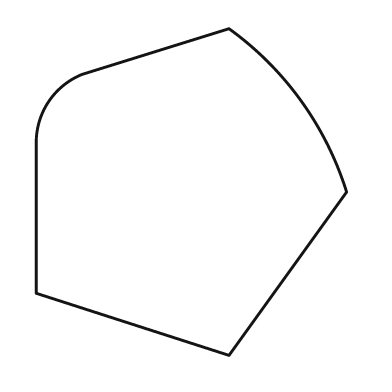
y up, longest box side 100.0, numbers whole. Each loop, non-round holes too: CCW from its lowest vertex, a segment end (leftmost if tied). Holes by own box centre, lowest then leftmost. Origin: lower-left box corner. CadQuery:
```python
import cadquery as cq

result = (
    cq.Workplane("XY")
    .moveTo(59.0, 0.0)
    .lineTo(95.0, 50.0)
    .threePointArc((81.0, 78.0), (59.0, 100.0))
    .lineTo(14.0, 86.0)
    .threePointArc((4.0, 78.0), (0.0, 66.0))
    .lineTo(0.0, 19.0)
    .close()
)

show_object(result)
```